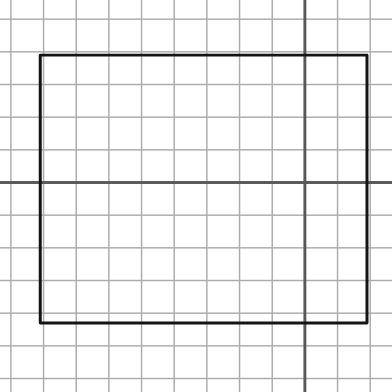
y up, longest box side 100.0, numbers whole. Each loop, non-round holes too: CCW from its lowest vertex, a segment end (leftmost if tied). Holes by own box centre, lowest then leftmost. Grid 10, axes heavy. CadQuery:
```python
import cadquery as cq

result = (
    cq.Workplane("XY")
    .moveTo(-81.0, -43.0)
    .lineTo(19.0, -43.0)
    .lineTo(19.0, 39.0)
    .lineTo(-81.0, 39.0)
    .close()
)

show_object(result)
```